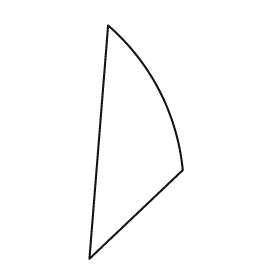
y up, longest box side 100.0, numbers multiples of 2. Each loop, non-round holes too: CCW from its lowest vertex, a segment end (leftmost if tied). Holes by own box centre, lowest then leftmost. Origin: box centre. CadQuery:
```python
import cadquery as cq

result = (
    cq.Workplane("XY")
    .moveTo(-20.0, -50.0)
    .lineTo(20.0, -12.0)
    .threePointArc((10.0, 22.0), (-12.0, 50.0))
    .close()
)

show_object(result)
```